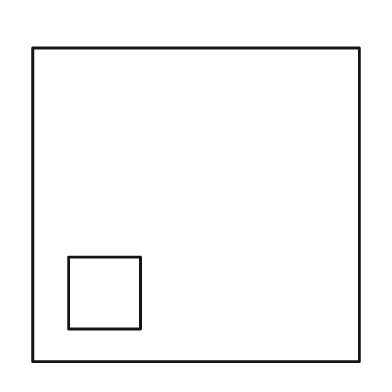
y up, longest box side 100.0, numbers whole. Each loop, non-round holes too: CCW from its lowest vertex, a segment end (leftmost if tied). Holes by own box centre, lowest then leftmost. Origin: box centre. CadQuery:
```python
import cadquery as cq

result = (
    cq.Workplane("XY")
    .moveTo(-50.0, -48.0)
    .lineTo(50.0, -48.0)
    .lineTo(50.0, 48.0)
    .lineTo(-50.0, 48.0)
    .close()
    .moveTo(-39.0, -38.0)
    .lineTo(-17.0, -38.0)
    .lineTo(-17.0, -16.0)
    .lineTo(-39.0, -16.0)
    .close()
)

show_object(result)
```